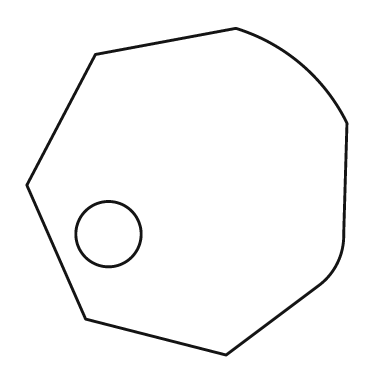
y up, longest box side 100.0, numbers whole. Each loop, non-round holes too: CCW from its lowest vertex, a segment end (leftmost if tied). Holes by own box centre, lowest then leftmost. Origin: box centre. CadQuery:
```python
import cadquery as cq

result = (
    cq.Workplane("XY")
    .moveTo(12.0, -50.0)
    .lineTo(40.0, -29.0)
    .threePointArc((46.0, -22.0), (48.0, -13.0))
    .lineTo(49.0, 21.0)
    .threePointArc((35.0, 39.0), (15.0, 50.0))
    .lineTo(-28.0, 42.0)
    .lineTo(-49.0, 2.0)
    .lineTo(-31.0, -39.0)
    .close()
    .moveTo(-24.0, -13.0)
    .circle(10.0)
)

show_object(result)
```